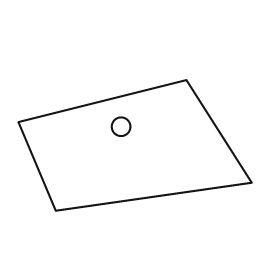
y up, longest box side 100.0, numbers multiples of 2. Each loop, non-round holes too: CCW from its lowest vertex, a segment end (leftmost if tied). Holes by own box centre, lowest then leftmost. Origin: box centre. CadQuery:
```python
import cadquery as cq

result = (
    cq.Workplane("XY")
    .moveTo(-34.0, -28.0)
    .lineTo(50.0, -16.0)
    .lineTo(22.0, 28.0)
    .lineTo(-50.0, 10.0)
    .close()
    .moveTo(-6.0, 8.0)
    .circle(4.0)
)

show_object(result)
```